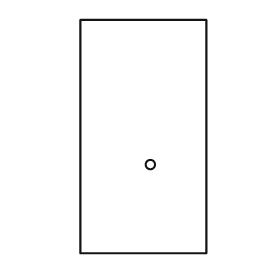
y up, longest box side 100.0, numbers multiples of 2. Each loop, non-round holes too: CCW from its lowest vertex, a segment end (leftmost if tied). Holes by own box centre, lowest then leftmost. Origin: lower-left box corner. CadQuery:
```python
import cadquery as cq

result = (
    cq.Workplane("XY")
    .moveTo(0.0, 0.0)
    .lineTo(54.0, 0.0)
    .lineTo(54.0, 100.0)
    .lineTo(0.0, 100.0)
    .close()
    .moveTo(30.0, 38.0)
    .circle(2.0)
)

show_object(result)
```